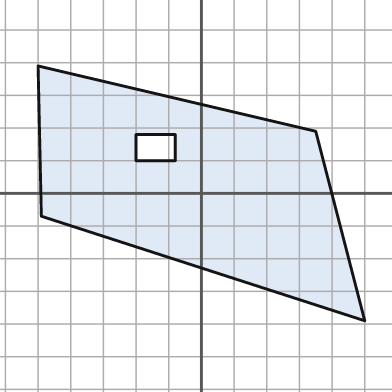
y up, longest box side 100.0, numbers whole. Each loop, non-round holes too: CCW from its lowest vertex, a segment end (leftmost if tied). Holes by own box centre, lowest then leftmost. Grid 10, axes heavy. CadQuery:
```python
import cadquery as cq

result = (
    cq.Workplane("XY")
    .moveTo(50.0, -39.0)
    .lineTo(35.0, 19.0)
    .lineTo(-50.0, 39.0)
    .lineTo(-49.0, -7.0)
    .close()
    .moveTo(-20.0, 10.0)
    .lineTo(-8.0, 10.0)
    .lineTo(-8.0, 18.0)
    .lineTo(-20.0, 18.0)
    .close()
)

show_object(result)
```